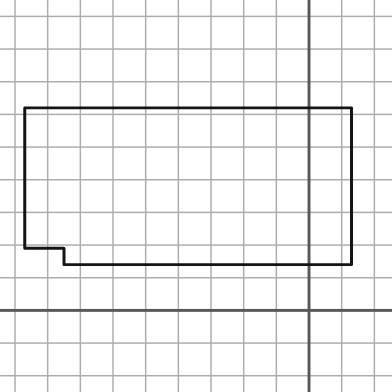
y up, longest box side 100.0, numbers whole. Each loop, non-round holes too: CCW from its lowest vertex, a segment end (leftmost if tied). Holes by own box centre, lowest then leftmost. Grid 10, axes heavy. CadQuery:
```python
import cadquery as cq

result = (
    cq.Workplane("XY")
    .moveTo(-75.0, 14.0)
    .lineTo(13.0, 14.0)
    .lineTo(13.0, 62.0)
    .lineTo(-87.0, 62.0)
    .lineTo(-87.0, 19.0)
    .lineTo(-75.0, 19.0)
    .close()
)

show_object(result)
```